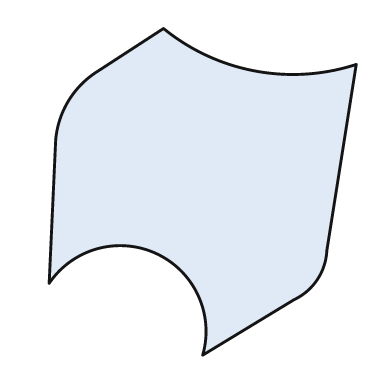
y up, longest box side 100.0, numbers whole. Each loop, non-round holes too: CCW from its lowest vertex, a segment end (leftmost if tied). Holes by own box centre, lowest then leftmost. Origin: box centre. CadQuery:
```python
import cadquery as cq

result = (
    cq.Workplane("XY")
    .moveTo(0.0, -50.0)
    .lineTo(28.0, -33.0)
    .threePointArc((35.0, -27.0), (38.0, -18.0))
    .lineTo(47.0, 39.0)
    .threePointArc((16.0, 37.0), (-12.0, 50.0))
    .lineTo(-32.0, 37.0)
    .threePointArc((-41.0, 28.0), (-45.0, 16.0))
    .lineTo(-47.0, -28.0)
    .threePointArc((-14.0, -19.0), (0.0, -50.0))
    .close()
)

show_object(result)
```